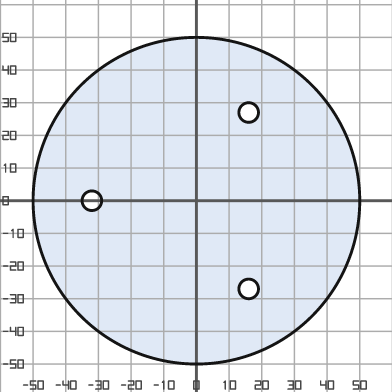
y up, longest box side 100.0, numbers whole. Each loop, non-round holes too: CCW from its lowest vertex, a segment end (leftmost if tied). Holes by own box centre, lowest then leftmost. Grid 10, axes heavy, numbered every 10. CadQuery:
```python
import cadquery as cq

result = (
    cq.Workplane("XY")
    .moveTo(0.0, 0.0)
    .circle(50.0)
    .moveTo(16.0, -27.0)
    .circle(3.0)
    .moveTo(-32.0, 0.0)
    .circle(3.0)
    .moveTo(16.0, 27.0)
    .circle(3.0)
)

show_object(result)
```